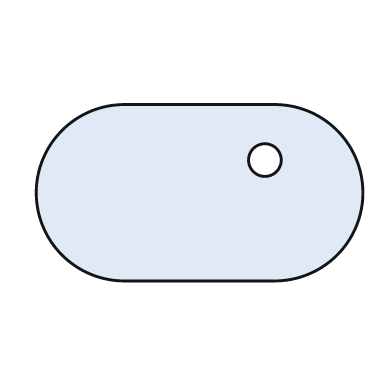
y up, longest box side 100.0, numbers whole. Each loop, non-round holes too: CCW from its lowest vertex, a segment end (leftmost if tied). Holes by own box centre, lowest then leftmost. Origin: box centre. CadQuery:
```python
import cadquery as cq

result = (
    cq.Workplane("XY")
    .moveTo(-23.0, -27.0)
    .lineTo(23.0, -27.0)
    .threePointArc((50.0, 0.0), (23.0, 27.0))
    .lineTo(-23.0, 27.0)
    .threePointArc((-50.0, 0.0), (-23.0, -27.0))
    .close()
    .moveTo(20.0, 10.0)
    .circle(5.0)
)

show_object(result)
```